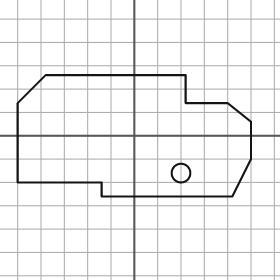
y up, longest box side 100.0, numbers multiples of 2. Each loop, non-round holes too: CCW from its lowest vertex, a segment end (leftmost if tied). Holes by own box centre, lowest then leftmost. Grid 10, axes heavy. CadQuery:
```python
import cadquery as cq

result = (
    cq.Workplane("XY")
    .moveTo(-14.0, -26.0)
    .lineTo(42.0, -26.0)
    .lineTo(50.0, -10.0)
    .lineTo(50.0, 6.0)
    .lineTo(40.0, 14.0)
    .lineTo(22.0, 14.0)
    .lineTo(22.0, 26.0)
    .lineTo(-38.0, 26.0)
    .lineTo(-50.0, 14.0)
    .lineTo(-50.0, -20.0)
    .lineTo(-14.0, -20.0)
    .close()
    .moveTo(20.0, -16.0)
    .circle(4.0)
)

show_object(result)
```